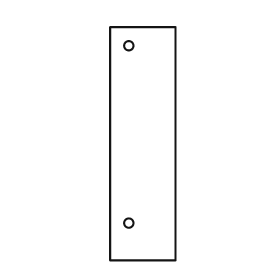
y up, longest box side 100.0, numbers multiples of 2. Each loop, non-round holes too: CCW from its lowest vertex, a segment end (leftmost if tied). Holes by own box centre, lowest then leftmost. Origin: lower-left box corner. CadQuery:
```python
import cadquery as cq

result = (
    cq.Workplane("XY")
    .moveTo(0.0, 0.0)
    .lineTo(28.0, 0.0)
    .lineTo(28.0, 100.0)
    .lineTo(0.0, 100.0)
    .close()
    .moveTo(8.0, 16.0)
    .circle(2.0)
    .moveTo(8.0, 92.0)
    .circle(2.0)
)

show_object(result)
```